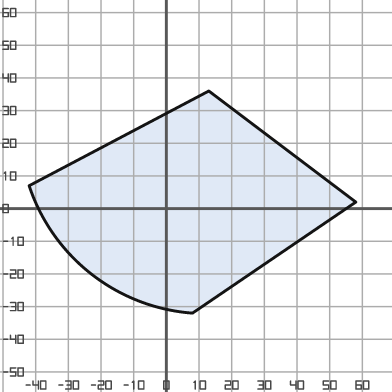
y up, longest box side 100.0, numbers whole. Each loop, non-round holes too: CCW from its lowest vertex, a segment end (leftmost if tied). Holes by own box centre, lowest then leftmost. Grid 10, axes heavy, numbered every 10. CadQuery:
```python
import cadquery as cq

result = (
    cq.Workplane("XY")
    .moveTo(8.0, -32.0)
    .lineTo(58.0, 2.0)
    .lineTo(13.0, 36.0)
    .lineTo(-42.0, 7.0)
    .threePointArc((-23.0, -20.0), (8.0, -32.0))
    .close()
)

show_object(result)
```